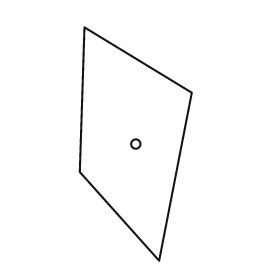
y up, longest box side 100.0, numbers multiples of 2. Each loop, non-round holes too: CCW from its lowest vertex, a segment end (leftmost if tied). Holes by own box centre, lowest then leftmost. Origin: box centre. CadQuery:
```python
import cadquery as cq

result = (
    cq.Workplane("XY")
    .moveTo(10.0, -50.0)
    .lineTo(24.0, 22.0)
    .lineTo(-22.0, 50.0)
    .lineTo(-24.0, -12.0)
    .close()
    .moveTo(0.0, 0.0)
    .circle(2.0)
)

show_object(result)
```